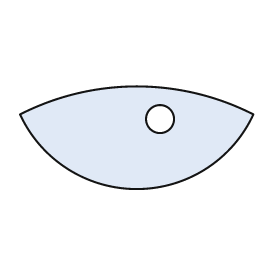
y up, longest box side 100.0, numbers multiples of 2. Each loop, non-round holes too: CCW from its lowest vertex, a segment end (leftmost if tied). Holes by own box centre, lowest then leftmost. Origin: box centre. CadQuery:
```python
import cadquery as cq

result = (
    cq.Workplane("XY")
    .moveTo(-50.0, 10.0)
    .threePointArc((0.0, -22.0), (50.0, 10.0))
    .threePointArc((0.0, 22.0), (-50.0, 10.0))
    .close()
    .moveTo(10.0, 8.0)
    .circle(6.0)
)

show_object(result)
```